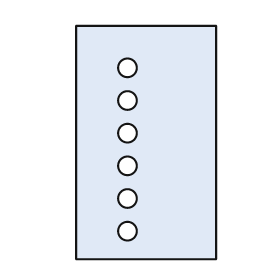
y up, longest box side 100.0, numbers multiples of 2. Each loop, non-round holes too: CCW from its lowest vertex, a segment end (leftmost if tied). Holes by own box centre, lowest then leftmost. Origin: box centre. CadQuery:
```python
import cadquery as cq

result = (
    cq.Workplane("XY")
    .moveTo(-30.0, -50.0)
    .lineTo(30.0, -50.0)
    .lineTo(30.0, 50.0)
    .lineTo(-30.0, 50.0)
    .close()
    .moveTo(-8.0, -38.0)
    .circle(4.0)
    .moveTo(-8.0, -24.0)
    .circle(4.0)
    .moveTo(-8.0, -10.0)
    .circle(4.0)
    .moveTo(-8.0, 4.0)
    .circle(4.0)
    .moveTo(-8.0, 18.0)
    .circle(4.0)
    .moveTo(-8.0, 32.0)
    .circle(4.0)
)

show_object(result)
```